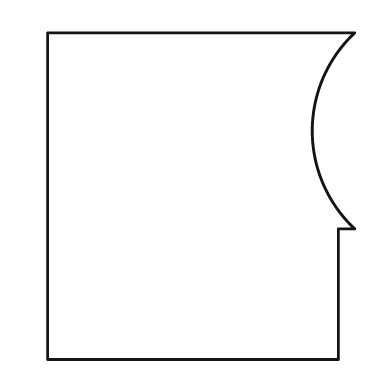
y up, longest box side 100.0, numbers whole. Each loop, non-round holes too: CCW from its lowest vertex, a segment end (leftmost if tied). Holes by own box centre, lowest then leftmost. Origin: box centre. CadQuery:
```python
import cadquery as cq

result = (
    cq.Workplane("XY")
    .moveTo(-47.0, -50.0)
    .lineTo(42.0, -50.0)
    .lineTo(42.0, -10.0)
    .lineTo(47.0, -10.0)
    .threePointArc((34.0, 20.0), (47.0, 50.0))
    .lineTo(-47.0, 50.0)
    .close()
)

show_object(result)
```